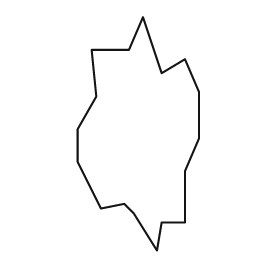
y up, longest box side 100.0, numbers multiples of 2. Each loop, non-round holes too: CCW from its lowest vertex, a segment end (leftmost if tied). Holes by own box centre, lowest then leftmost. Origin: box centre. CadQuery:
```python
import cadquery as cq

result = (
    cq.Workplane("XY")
    .moveTo(8.0, -50.0)
    .lineTo(10.0, -38.0)
    .lineTo(20.0, -38.0)
    .lineTo(20.0, -16.0)
    .lineTo(26.0, -2.0)
    .lineTo(26.0, 18.0)
    .lineTo(20.0, 32.0)
    .lineTo(10.0, 26.0)
    .lineTo(2.0, 50.0)
    .lineTo(-4.0, 36.0)
    .lineTo(-20.0, 36.0)
    .lineTo(-18.0, 16.0)
    .lineTo(-26.0, 2.0)
    .lineTo(-26.0, -12.0)
    .lineTo(-16.0, -32.0)
    .lineTo(-6.0, -30.0)
    .lineTo(-2.0, -34.0)
    .close()
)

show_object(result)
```